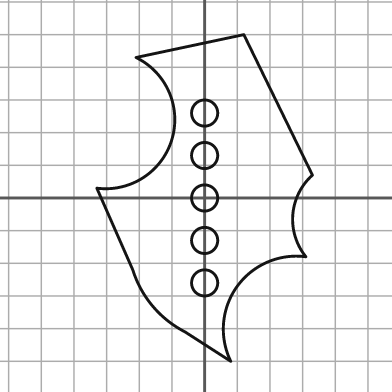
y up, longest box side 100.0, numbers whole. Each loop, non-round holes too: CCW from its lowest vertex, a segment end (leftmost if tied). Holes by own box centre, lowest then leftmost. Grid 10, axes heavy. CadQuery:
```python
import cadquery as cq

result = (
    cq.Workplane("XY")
    .moveTo(8.0, -50.0)
    .threePointArc((10.0, -27.0), (31.0, -18.0))
    .threePointArc((27.0, -5.0), (33.0, 7.0))
    .lineTo(12.0, 50.0)
    .lineTo(-21.0, 43.0)
    .threePointArc((-10.0, 18.0), (-33.0, 3.0))
    .lineTo(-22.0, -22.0)
    .threePointArc((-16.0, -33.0), (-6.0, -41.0))
    .close()
    .moveTo(0.0, -26.0)
    .circle(4.0)
    .moveTo(0.0, -13.0)
    .circle(4.0)
    .moveTo(0.0, 0.0)
    .circle(4.0)
    .moveTo(0.0, 13.0)
    .circle(4.0)
    .moveTo(0.0, 26.0)
    .circle(4.0)
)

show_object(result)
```